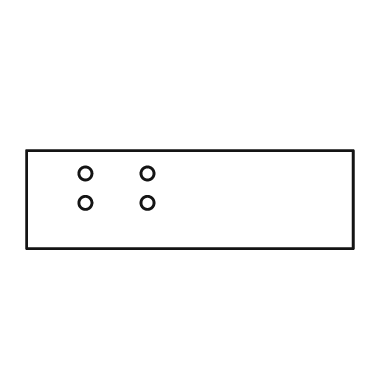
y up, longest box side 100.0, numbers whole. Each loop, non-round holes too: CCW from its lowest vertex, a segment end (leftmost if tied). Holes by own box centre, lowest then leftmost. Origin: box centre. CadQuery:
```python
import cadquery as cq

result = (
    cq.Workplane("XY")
    .moveTo(-50.0, -15.0)
    .lineTo(50.0, -15.0)
    .lineTo(50.0, 15.0)
    .lineTo(-50.0, 15.0)
    .close()
    .moveTo(-32.0, -1.0)
    .circle(2.0)
    .moveTo(-13.0, -1.0)
    .circle(2.0)
    .moveTo(-32.0, 8.0)
    .circle(2.0)
    .moveTo(-13.0, 8.0)
    .circle(2.0)
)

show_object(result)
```